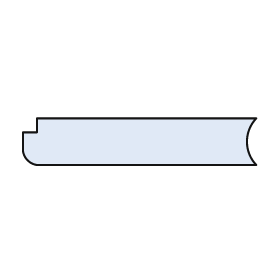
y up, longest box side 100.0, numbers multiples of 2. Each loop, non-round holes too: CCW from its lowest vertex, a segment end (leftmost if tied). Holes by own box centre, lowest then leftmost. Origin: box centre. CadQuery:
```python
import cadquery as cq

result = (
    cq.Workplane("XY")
    .moveTo(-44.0, -10.0)
    .lineTo(50.0, -10.0)
    .threePointArc((46.0, 0.0), (50.0, 10.0))
    .lineTo(-44.0, 10.0)
    .lineTo(-44.0, 4.0)
    .lineTo(-50.0, 4.0)
    .lineTo(-50.0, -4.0)
    .threePointArc((-48.0, -8.0), (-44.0, -10.0))
    .close()
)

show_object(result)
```